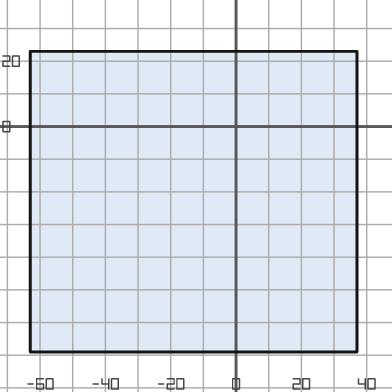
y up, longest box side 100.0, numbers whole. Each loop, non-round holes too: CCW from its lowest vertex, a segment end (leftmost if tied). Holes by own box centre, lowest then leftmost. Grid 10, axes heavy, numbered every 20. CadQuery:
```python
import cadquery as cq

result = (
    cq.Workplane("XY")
    .moveTo(-63.0, -69.0)
    .lineTo(37.0, -69.0)
    .lineTo(37.0, 23.0)
    .lineTo(-63.0, 23.0)
    .close()
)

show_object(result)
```